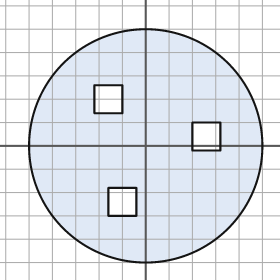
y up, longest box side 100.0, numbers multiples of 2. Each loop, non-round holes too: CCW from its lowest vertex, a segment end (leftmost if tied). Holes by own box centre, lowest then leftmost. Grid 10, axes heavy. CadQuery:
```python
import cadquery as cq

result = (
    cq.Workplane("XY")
    .moveTo(0.0, 0.0)
    .circle(50.0)
    .moveTo(-16.0, -30.0)
    .lineTo(-4.0, -30.0)
    .lineTo(-4.0, -18.0)
    .lineTo(-16.0, -18.0)
    .close()
    .moveTo(20.0, -2.0)
    .lineTo(32.0, -2.0)
    .lineTo(32.0, 10.0)
    .lineTo(20.0, 10.0)
    .close()
    .moveTo(-22.0, 14.0)
    .lineTo(-10.0, 14.0)
    .lineTo(-10.0, 26.0)
    .lineTo(-22.0, 26.0)
    .close()
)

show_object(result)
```